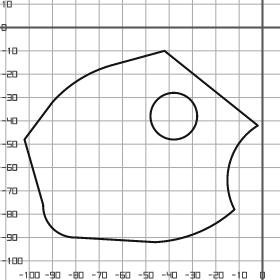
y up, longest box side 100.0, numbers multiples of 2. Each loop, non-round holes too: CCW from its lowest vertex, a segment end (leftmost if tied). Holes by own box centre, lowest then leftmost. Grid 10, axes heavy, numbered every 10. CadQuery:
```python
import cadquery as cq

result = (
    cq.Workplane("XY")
    .moveTo(-46.0, -92.0)
    .threePointArc((-28.0, -88.0), (-12.0, -78.0))
    .threePointArc((-14.0, -58.0), (-2.0, -42.0))
    .lineTo(-42.0, -10.0)
    .lineTo(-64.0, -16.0)
    .threePointArc((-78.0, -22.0), (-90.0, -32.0))
    .lineTo(-102.0, -48.0)
    .lineTo(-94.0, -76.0)
    .threePointArc((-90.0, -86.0), (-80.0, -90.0))
    .close()
    .moveTo(-38.0, -38.0)
    .circle(10.0)
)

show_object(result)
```